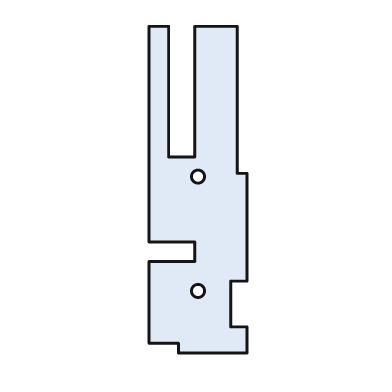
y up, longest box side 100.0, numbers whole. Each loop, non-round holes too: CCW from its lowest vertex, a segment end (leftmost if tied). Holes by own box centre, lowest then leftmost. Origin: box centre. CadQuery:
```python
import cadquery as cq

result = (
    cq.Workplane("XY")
    .moveTo(-6.0, -50.0)
    .lineTo(15.0, -50.0)
    .lineTo(15.0, -42.0)
    .lineTo(10.0, -42.0)
    .lineTo(10.0, -28.0)
    .lineTo(15.0, -28.0)
    .lineTo(15.0, 5.0)
    .lineTo(12.0, 5.0)
    .lineTo(12.0, 50.0)
    .lineTo(-1.0, 50.0)
    .lineTo(-1.0, 10.0)
    .lineTo(-9.0, 10.0)
    .lineTo(-9.0, 50.0)
    .lineTo(-15.0, 50.0)
    .lineTo(-15.0, -16.0)
    .lineTo(-1.0, -16.0)
    .lineTo(-1.0, -22.0)
    .lineTo(-15.0, -22.0)
    .lineTo(-15.0, -47.0)
    .lineTo(-6.0, -47.0)
    .close()
    .moveTo(0.0, -31.0)
    .circle(2.0)
    .moveTo(0.0, 4.0)
    .circle(2.0)
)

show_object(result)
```